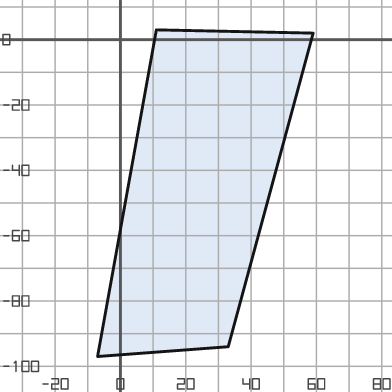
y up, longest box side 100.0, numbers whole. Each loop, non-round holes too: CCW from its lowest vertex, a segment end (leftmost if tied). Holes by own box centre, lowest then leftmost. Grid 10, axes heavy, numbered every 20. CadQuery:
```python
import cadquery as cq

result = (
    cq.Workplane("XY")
    .moveTo(-7.0, -97.0)
    .lineTo(33.0, -94.0)
    .lineTo(59.0, 2.0)
    .lineTo(11.0, 3.0)
    .close()
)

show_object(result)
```